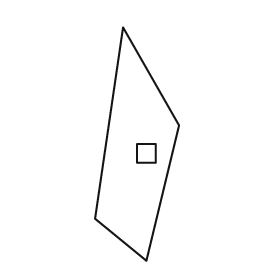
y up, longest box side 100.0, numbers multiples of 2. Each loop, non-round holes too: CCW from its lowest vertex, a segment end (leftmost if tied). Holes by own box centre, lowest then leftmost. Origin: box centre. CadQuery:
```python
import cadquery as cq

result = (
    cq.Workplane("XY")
    .moveTo(4.0, -50.0)
    .lineTo(18.0, 8.0)
    .lineTo(-6.0, 50.0)
    .lineTo(-18.0, -32.0)
    .close()
    .moveTo(0.0, -8.0)
    .lineTo(8.0, -8.0)
    .lineTo(8.0, 0.0)
    .lineTo(0.0, 0.0)
    .close()
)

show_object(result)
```